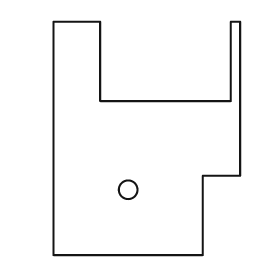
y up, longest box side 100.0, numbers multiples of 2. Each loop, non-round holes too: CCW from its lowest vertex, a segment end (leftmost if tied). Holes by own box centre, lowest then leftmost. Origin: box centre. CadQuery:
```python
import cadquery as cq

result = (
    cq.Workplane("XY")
    .moveTo(-40.0, -50.0)
    .lineTo(24.0, -50.0)
    .lineTo(24.0, -16.0)
    .lineTo(40.0, -16.0)
    .lineTo(40.0, 50.0)
    .lineTo(36.0, 50.0)
    .lineTo(36.0, 16.0)
    .lineTo(-20.0, 16.0)
    .lineTo(-20.0, 50.0)
    .lineTo(-40.0, 50.0)
    .close()
    .moveTo(-8.0, -22.0)
    .circle(4.0)
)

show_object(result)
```